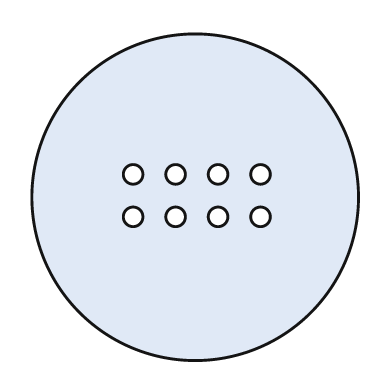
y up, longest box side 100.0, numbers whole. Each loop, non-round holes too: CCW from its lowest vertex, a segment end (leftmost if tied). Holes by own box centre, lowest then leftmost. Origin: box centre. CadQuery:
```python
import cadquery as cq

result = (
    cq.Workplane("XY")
    .moveTo(0.0, 0.0)
    .circle(50.0)
    .moveTo(-19.0, -6.0)
    .circle(3.0)
    .moveTo(-6.0, -6.0)
    .circle(3.0)
    .moveTo(7.0, -6.0)
    .circle(3.0)
    .moveTo(20.0, -6.0)
    .circle(3.0)
    .moveTo(-19.0, 7.0)
    .circle(3.0)
    .moveTo(-6.0, 7.0)
    .circle(3.0)
    .moveTo(7.0, 7.0)
    .circle(3.0)
    .moveTo(20.0, 7.0)
    .circle(3.0)
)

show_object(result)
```